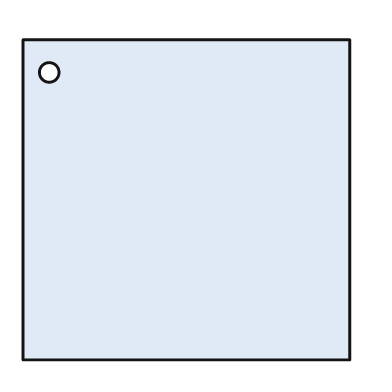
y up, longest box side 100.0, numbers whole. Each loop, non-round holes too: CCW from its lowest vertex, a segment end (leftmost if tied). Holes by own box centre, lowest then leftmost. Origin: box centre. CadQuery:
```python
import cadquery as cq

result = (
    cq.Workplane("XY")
    .moveTo(-50.0, -49.0)
    .lineTo(50.0, -49.0)
    .lineTo(50.0, 49.0)
    .lineTo(-50.0, 49.0)
    .close()
    .moveTo(-42.0, 39.0)
    .circle(3.0)
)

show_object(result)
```